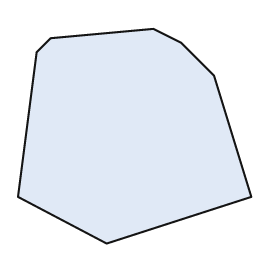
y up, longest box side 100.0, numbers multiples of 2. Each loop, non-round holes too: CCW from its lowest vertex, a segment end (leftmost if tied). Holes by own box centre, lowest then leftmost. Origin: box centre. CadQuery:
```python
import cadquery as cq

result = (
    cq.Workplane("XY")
    .moveTo(-12.0, -46.0)
    .lineTo(50.0, -26.0)
    .lineTo(34.0, 26.0)
    .lineTo(20.0, 40.0)
    .lineTo(8.0, 46.0)
    .lineTo(-36.0, 42.0)
    .lineTo(-42.0, 36.0)
    .lineTo(-50.0, -26.0)
    .close()
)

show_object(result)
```